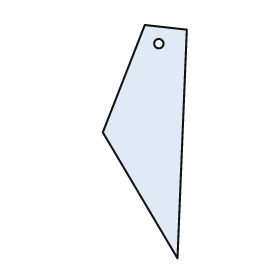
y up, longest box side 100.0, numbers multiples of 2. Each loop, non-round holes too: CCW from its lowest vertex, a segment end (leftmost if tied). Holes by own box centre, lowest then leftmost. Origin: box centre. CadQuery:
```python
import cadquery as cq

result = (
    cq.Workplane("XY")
    .moveTo(14.0, -50.0)
    .lineTo(18.0, 48.0)
    .lineTo(0.0, 50.0)
    .lineTo(-18.0, 4.0)
    .close()
    .moveTo(6.0, 42.0)
    .circle(2.0)
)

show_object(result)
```